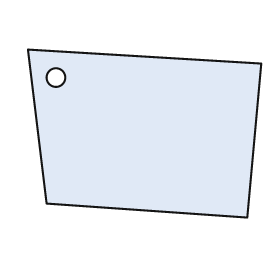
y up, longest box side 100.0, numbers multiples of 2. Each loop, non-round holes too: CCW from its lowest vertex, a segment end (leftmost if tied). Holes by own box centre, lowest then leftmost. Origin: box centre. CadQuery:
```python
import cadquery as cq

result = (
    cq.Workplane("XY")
    .moveTo(44.0, -36.0)
    .lineTo(50.0, 30.0)
    .lineTo(-50.0, 36.0)
    .lineTo(-42.0, -30.0)
    .close()
    .moveTo(-38.0, 24.0)
    .circle(4.0)
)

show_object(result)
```